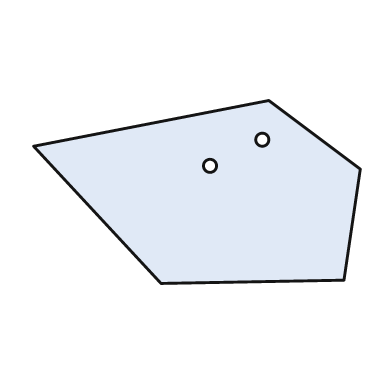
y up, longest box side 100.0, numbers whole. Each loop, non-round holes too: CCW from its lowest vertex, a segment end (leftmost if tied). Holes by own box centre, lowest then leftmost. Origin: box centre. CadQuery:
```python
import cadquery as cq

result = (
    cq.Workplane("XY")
    .moveTo(-11.0, -28.0)
    .lineTo(45.0, -27.0)
    .lineTo(50.0, 7.0)
    .lineTo(22.0, 28.0)
    .lineTo(-50.0, 14.0)
    .close()
    .moveTo(4.0, 8.0)
    .circle(2.0)
    .moveTo(20.0, 16.0)
    .circle(2.0)
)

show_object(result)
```